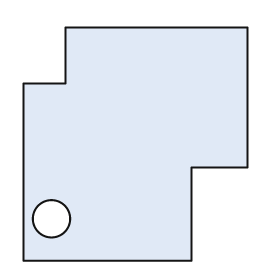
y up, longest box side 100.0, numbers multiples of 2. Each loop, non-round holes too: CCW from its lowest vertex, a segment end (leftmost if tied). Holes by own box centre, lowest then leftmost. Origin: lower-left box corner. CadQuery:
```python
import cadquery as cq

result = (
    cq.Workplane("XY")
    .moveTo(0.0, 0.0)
    .lineTo(72.0, 0.0)
    .lineTo(72.0, 40.0)
    .lineTo(96.0, 40.0)
    .lineTo(96.0, 100.0)
    .lineTo(18.0, 100.0)
    .lineTo(18.0, 76.0)
    .lineTo(0.0, 76.0)
    .close()
    .moveTo(12.0, 18.0)
    .circle(8.0)
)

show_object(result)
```